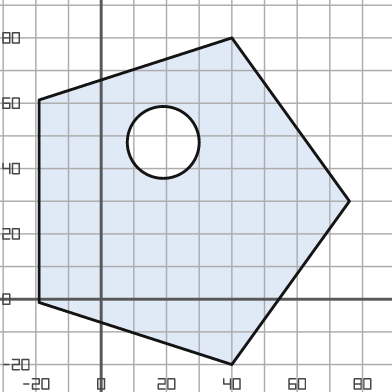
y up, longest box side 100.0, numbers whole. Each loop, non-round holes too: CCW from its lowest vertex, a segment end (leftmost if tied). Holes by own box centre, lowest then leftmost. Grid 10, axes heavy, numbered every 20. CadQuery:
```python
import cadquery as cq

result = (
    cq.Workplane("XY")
    .moveTo(40.0, -20.0)
    .lineTo(76.0, 30.0)
    .lineTo(40.0, 80.0)
    .lineTo(-19.0, 61.0)
    .lineTo(-19.0, -1.0)
    .close()
    .moveTo(19.0, 48.0)
    .circle(11.0)
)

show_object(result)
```